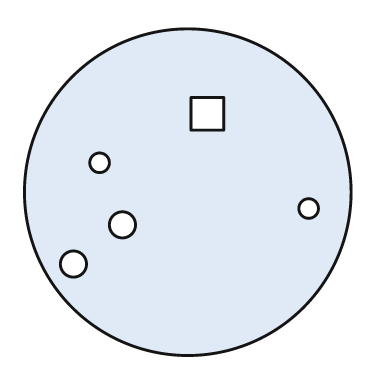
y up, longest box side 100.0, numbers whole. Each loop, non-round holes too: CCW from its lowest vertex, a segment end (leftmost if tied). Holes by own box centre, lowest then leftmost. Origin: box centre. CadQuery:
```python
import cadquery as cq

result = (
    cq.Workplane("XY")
    .moveTo(0.0, 0.0)
    .circle(50.0)
    .moveTo(-35.0, -22.0)
    .circle(4.0)
    .moveTo(-20.0, -10.0)
    .circle(4.0)
    .moveTo(37.0, -5.0)
    .circle(3.0)
    .moveTo(-27.0, 9.0)
    .circle(3.0)
    .moveTo(1.0, 19.0)
    .lineTo(11.0, 19.0)
    .lineTo(11.0, 29.0)
    .lineTo(1.0, 29.0)
    .close()
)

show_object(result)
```